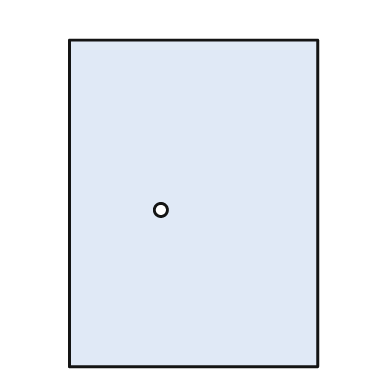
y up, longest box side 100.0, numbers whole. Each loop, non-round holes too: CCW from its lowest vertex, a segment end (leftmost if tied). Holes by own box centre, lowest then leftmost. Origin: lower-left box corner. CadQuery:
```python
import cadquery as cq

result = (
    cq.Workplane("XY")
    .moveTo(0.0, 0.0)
    .lineTo(76.0, 0.0)
    .lineTo(76.0, 100.0)
    .lineTo(0.0, 100.0)
    .close()
    .moveTo(28.0, 48.0)
    .circle(2.0)
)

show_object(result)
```